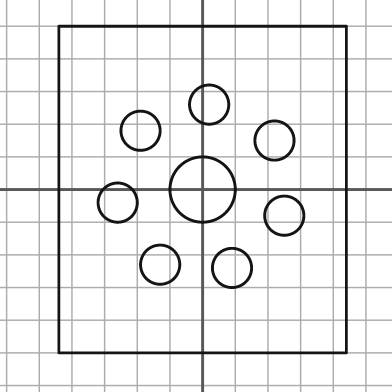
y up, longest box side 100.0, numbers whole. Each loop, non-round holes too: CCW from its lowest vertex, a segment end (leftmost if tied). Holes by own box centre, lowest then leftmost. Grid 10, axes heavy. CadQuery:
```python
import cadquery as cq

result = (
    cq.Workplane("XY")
    .moveTo(-44.0, -50.0)
    .lineTo(44.0, -50.0)
    .lineTo(44.0, 50.0)
    .lineTo(-44.0, 50.0)
    .close()
    .moveTo(9.0, -24.0)
    .circle(6.0)
    .moveTo(-13.0, -23.0)
    .circle(6.0)
    .moveTo(25.0, -8.0)
    .circle(6.0)
    .moveTo(-26.0, -4.0)
    .circle(6.0)
    .moveTo(0.0, 0.0)
    .circle(10.0)
    .moveTo(22.0, 15.0)
    .circle(6.0)
    .moveTo(-19.0, 18.0)
    .circle(6.0)
    .moveTo(2.0, 26.0)
    .circle(6.0)
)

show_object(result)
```